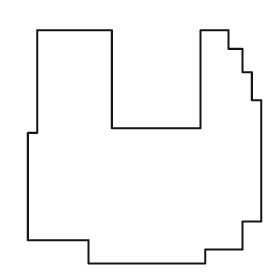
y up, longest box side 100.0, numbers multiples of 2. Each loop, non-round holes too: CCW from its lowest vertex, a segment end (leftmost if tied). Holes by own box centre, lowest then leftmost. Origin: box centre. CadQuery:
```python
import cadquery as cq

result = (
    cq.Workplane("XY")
    .moveTo(-24.0, -50.0)
    .lineTo(26.0, -50.0)
    .lineTo(26.0, -44.0)
    .lineTo(42.0, -44.0)
    .lineTo(42.0, -32.0)
    .lineTo(50.0, -32.0)
    .lineTo(50.0, 20.0)
    .lineTo(46.0, 20.0)
    .lineTo(46.0, 32.0)
    .lineTo(42.0, 32.0)
    .lineTo(42.0, 42.0)
    .lineTo(36.0, 42.0)
    .lineTo(36.0, 50.0)
    .lineTo(24.0, 50.0)
    .lineTo(24.0, 8.0)
    .lineTo(-14.0, 8.0)
    .lineTo(-14.0, 50.0)
    .lineTo(-46.0, 50.0)
    .lineTo(-46.0, 6.0)
    .lineTo(-50.0, 6.0)
    .lineTo(-50.0, -40.0)
    .lineTo(-24.0, -40.0)
    .close()
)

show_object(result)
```